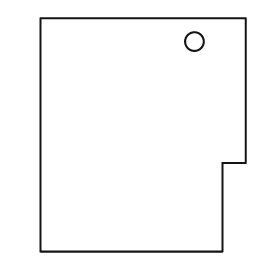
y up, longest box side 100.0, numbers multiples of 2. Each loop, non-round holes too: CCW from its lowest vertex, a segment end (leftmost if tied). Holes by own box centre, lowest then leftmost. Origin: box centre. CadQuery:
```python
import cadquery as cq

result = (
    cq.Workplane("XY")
    .moveTo(-44.0, -50.0)
    .lineTo(34.0, -50.0)
    .lineTo(34.0, -12.0)
    .lineTo(44.0, -12.0)
    .lineTo(44.0, 50.0)
    .lineTo(-44.0, 50.0)
    .close()
    .moveTo(22.0, 40.0)
    .circle(4.0)
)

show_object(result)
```